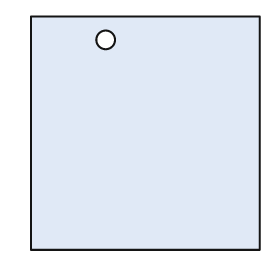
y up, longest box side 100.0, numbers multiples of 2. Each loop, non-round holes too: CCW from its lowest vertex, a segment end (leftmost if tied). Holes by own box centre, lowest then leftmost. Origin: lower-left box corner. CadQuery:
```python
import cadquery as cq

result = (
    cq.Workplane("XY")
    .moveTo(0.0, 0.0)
    .lineTo(98.0, 0.0)
    .lineTo(98.0, 100.0)
    .lineTo(0.0, 100.0)
    .close()
    .moveTo(32.0, 90.0)
    .circle(4.0)
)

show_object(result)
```